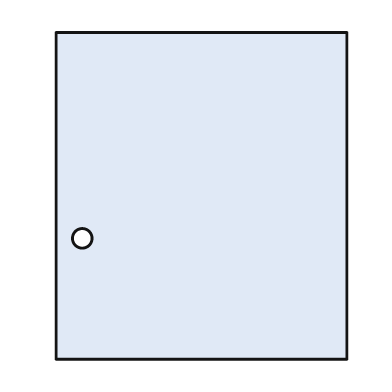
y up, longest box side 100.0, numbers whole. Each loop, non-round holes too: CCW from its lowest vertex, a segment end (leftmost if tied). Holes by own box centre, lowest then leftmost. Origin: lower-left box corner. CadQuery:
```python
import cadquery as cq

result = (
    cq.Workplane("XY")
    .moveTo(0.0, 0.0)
    .lineTo(89.0, 0.0)
    .lineTo(89.0, 100.0)
    .lineTo(0.0, 100.0)
    .close()
    .moveTo(8.0, 37.0)
    .circle(3.0)
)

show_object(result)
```